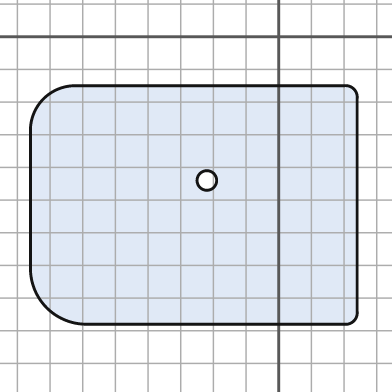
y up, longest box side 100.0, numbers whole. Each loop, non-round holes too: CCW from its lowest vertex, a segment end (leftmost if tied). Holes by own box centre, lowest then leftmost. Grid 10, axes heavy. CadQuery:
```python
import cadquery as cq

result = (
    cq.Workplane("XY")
    .moveTo(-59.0, -88.0)
    .lineTo(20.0, -88.0)
    .threePointArc((23.0, -87.0), (24.0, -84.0))
    .lineTo(24.0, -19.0)
    .threePointArc((23.0, -16.0), (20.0, -15.0))
    .lineTo(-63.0, -15.0)
    .threePointArc((-72.0, -19.0), (-76.0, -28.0))
    .lineTo(-76.0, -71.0)
    .threePointArc((-71.0, -83.0), (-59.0, -88.0))
    .close()
    .moveTo(-22.0, -44.0)
    .circle(3.0)
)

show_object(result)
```